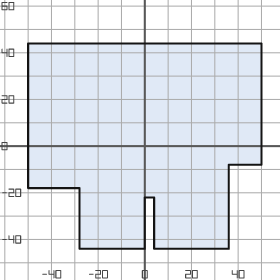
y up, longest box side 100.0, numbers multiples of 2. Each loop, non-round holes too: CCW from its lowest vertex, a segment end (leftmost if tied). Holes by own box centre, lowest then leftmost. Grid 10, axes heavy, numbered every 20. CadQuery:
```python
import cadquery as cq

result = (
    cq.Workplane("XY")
    .moveTo(-28.0, -44.0)
    .lineTo(0.0, -44.0)
    .lineTo(0.0, -22.0)
    .lineTo(4.0, -22.0)
    .lineTo(4.0, -44.0)
    .lineTo(36.0, -44.0)
    .lineTo(36.0, -8.0)
    .lineTo(50.0, -8.0)
    .lineTo(50.0, 44.0)
    .lineTo(-50.0, 44.0)
    .lineTo(-50.0, -18.0)
    .lineTo(-28.0, -18.0)
    .close()
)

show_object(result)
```